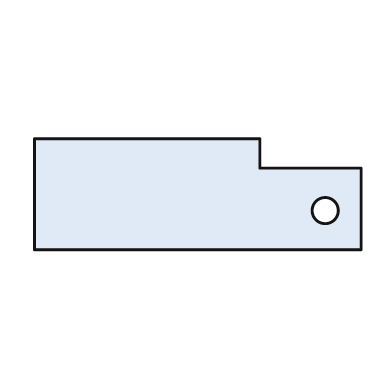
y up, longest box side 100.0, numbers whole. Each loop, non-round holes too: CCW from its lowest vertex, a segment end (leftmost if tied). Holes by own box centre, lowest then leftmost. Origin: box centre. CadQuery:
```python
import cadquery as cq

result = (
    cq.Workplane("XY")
    .moveTo(-50.0, -17.0)
    .lineTo(50.0, -17.0)
    .lineTo(50.0, 8.0)
    .lineTo(19.0, 8.0)
    .lineTo(19.0, 17.0)
    .lineTo(-50.0, 17.0)
    .close()
    .moveTo(39.0, -5.0)
    .circle(4.0)
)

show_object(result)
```